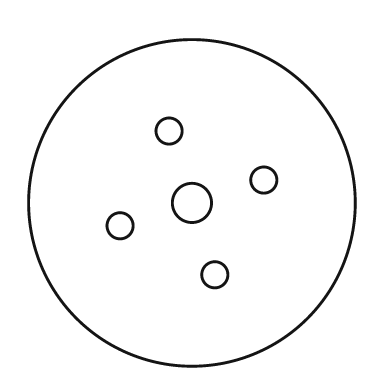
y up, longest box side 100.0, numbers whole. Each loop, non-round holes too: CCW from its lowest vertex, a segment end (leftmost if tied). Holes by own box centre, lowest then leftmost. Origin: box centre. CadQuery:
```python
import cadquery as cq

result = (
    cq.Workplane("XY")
    .moveTo(0.0, 0.0)
    .circle(50.0)
    .moveTo(7.0, -22.0)
    .circle(4.0)
    .moveTo(-22.0, -7.0)
    .circle(4.0)
    .moveTo(0.0, 0.0)
    .circle(6.0)
    .moveTo(22.0, 7.0)
    .circle(4.0)
    .moveTo(-7.0, 22.0)
    .circle(4.0)
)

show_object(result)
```